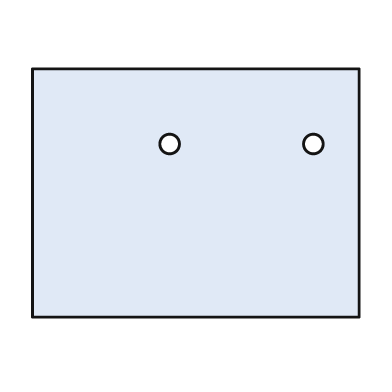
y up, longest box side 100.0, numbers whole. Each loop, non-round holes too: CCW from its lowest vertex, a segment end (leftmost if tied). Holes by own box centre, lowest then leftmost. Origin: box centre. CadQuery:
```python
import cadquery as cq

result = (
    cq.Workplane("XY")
    .moveTo(-50.0, -38.0)
    .lineTo(50.0, -38.0)
    .lineTo(50.0, 38.0)
    .lineTo(-50.0, 38.0)
    .close()
    .moveTo(-8.0, 15.0)
    .circle(3.0)
    .moveTo(36.0, 15.0)
    .circle(3.0)
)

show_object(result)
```